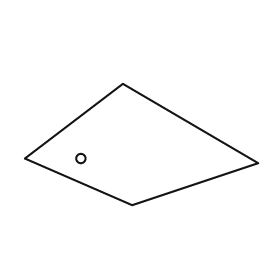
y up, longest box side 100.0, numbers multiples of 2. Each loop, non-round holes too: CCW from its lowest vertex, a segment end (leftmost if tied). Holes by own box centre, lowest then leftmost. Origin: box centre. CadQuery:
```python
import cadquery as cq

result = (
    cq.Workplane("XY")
    .moveTo(-4.0, -26.0)
    .lineTo(50.0, -8.0)
    .lineTo(-8.0, 26.0)
    .lineTo(-50.0, -6.0)
    .close()
    .moveTo(-26.0, -6.0)
    .circle(2.0)
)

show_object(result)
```